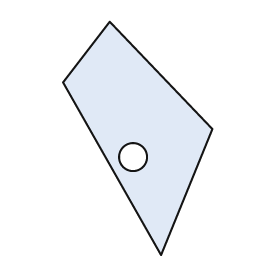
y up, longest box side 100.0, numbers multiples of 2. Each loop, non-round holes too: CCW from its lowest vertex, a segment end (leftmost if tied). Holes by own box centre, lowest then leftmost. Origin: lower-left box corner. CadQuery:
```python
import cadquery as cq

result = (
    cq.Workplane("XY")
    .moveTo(42.0, 0.0)
    .lineTo(64.0, 54.0)
    .lineTo(20.0, 100.0)
    .lineTo(0.0, 74.0)
    .close()
    .moveTo(30.0, 42.0)
    .circle(6.0)
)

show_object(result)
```